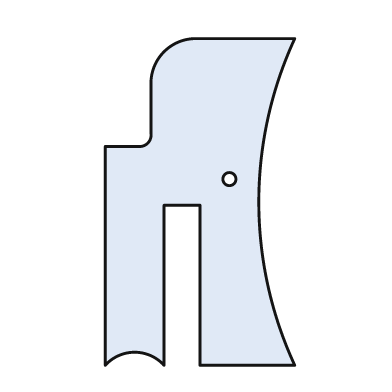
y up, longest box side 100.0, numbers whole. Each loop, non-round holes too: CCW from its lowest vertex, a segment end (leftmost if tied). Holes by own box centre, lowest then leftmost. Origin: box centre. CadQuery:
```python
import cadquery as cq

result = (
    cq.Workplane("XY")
    .moveTo(-29.0, -50.0)
    .threePointArc((-20.0, -46.0), (-11.0, -50.0))
    .lineTo(-11.0, -1.0)
    .lineTo(0.0, -1.0)
    .lineTo(0.0, -50.0)
    .lineTo(29.0, -50.0)
    .threePointArc((18.0, 0.0), (29.0, 50.0))
    .lineTo(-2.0, 50.0)
    .threePointArc((-11.0, 46.0), (-15.0, 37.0))
    .lineTo(-15.0, 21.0)
    .threePointArc((-16.0, 18.0), (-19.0, 17.0))
    .lineTo(-29.0, 17.0)
    .close()
    .moveTo(9.0, 7.0)
    .circle(2.0)
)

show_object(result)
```